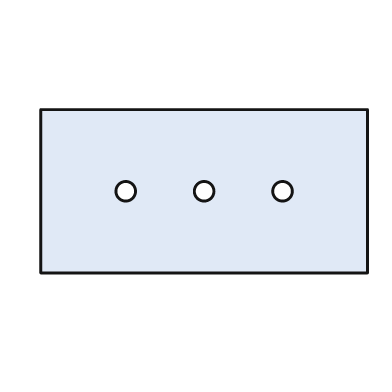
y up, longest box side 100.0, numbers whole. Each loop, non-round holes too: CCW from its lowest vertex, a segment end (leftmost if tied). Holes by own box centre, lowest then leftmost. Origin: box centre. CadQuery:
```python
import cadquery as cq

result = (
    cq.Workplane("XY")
    .moveTo(-50.0, -25.0)
    .lineTo(50.0, -25.0)
    .lineTo(50.0, 25.0)
    .lineTo(-50.0, 25.0)
    .close()
    .moveTo(-24.0, 0.0)
    .circle(3.0)
    .moveTo(0.0, 0.0)
    .circle(3.0)
    .moveTo(24.0, 0.0)
    .circle(3.0)
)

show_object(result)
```